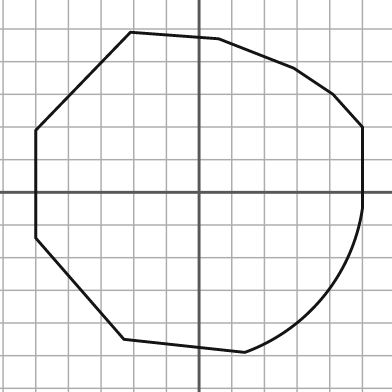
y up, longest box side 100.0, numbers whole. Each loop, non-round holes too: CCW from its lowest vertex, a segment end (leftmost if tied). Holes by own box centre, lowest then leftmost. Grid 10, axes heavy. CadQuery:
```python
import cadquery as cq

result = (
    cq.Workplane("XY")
    .moveTo(14.0, -49.0)
    .threePointArc((38.0, -32.0), (50.0, -5.0))
    .lineTo(50.0, 20.0)
    .lineTo(41.0, 30.0)
    .lineTo(29.0, 38.0)
    .lineTo(6.0, 47.0)
    .lineTo(-21.0, 49.0)
    .lineTo(-50.0, 19.0)
    .lineTo(-50.0, -14.0)
    .lineTo(-23.0, -45.0)
    .close()
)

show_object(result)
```